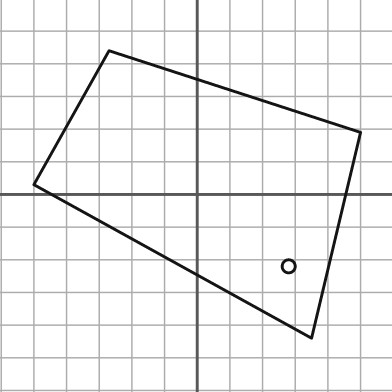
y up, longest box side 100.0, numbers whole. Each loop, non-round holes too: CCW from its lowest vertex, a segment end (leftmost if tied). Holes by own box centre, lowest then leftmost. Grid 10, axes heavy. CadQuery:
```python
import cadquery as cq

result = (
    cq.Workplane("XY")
    .moveTo(35.0, -44.0)
    .lineTo(50.0, 19.0)
    .lineTo(-27.0, 44.0)
    .lineTo(-50.0, 3.0)
    .close()
    .moveTo(28.0, -22.0)
    .circle(2.0)
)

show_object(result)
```